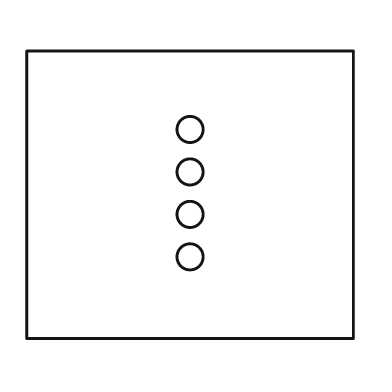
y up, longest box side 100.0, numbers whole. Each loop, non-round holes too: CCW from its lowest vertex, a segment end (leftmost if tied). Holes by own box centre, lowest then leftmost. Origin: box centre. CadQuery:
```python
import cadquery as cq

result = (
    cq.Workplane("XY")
    .moveTo(-50.0, -44.0)
    .lineTo(50.0, -44.0)
    .lineTo(50.0, 44.0)
    .lineTo(-50.0, 44.0)
    .close()
    .moveTo(0.0, -19.0)
    .circle(4.0)
    .moveTo(0.0, -6.0)
    .circle(4.0)
    .moveTo(0.0, 7.0)
    .circle(4.0)
    .moveTo(0.0, 20.0)
    .circle(4.0)
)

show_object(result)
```